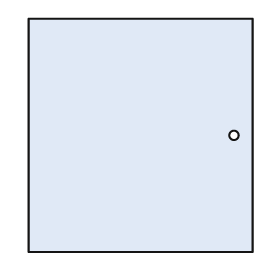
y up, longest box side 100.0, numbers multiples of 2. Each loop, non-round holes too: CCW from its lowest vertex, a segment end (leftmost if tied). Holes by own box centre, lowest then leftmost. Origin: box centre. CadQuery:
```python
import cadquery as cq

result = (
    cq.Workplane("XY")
    .moveTo(-48.0, -50.0)
    .lineTo(48.0, -50.0)
    .lineTo(48.0, 50.0)
    .lineTo(-48.0, 50.0)
    .close()
    .moveTo(40.0, 0.0)
    .circle(2.0)
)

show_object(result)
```